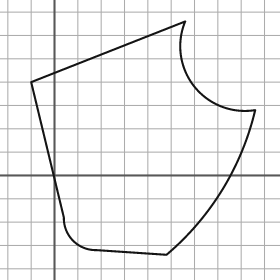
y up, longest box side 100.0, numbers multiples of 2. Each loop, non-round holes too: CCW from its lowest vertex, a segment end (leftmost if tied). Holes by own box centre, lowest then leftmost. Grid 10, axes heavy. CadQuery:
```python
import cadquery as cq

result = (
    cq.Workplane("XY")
    .moveTo(48.0, -34.0)
    .threePointArc((72.0, -6.0), (86.0, 28.0))
    .threePointArc((60.0, 38.0), (56.0, 66.0))
    .lineTo(-10.0, 40.0)
    .lineTo(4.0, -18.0)
    .threePointArc((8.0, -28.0), (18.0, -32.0))
    .close()
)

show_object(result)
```